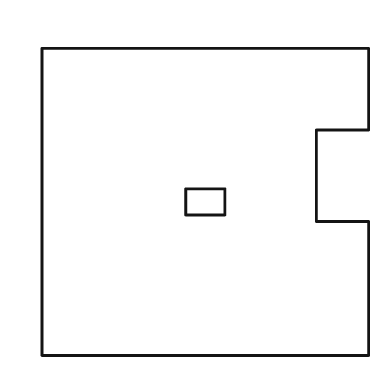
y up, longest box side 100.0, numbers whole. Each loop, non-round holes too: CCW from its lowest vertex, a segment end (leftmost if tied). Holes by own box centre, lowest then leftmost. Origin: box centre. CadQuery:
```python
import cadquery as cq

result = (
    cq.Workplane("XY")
    .moveTo(-50.0, -47.0)
    .lineTo(50.0, -47.0)
    .lineTo(50.0, -6.0)
    .lineTo(34.0, -6.0)
    .lineTo(34.0, 22.0)
    .lineTo(50.0, 22.0)
    .lineTo(50.0, 47.0)
    .lineTo(-50.0, 47.0)
    .close()
    .moveTo(-6.0, -4.0)
    .lineTo(6.0, -4.0)
    .lineTo(6.0, 4.0)
    .lineTo(-6.0, 4.0)
    .close()
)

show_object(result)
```